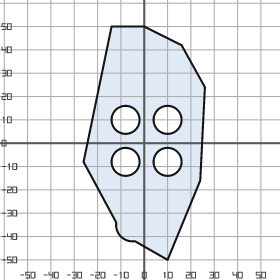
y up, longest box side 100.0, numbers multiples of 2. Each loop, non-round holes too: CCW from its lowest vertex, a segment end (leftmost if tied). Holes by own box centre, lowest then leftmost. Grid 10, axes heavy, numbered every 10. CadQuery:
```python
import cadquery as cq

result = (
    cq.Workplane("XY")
    .moveTo(10.0, -50.0)
    .lineTo(24.0, -16.0)
    .lineTo(26.0, 24.0)
    .lineTo(16.0, 42.0)
    .lineTo(0.0, 50.0)
    .lineTo(-14.0, 50.0)
    .lineTo(-26.0, -8.0)
    .lineTo(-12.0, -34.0)
    .threePointArc((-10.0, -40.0), (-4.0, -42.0))
    .close()
    .moveTo(-8.0, -8.0)
    .circle(6.0)
    .moveTo(10.0, -8.0)
    .circle(6.0)
    .moveTo(-8.0, 10.0)
    .circle(6.0)
    .moveTo(10.0, 10.0)
    .circle(6.0)
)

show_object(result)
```